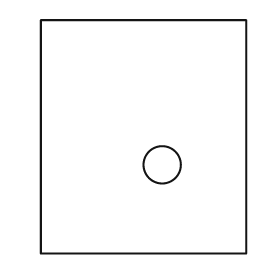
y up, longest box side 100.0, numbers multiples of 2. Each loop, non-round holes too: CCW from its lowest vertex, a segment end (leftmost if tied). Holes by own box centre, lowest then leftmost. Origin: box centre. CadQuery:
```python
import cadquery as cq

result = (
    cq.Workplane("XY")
    .moveTo(-44.0, -50.0)
    .lineTo(44.0, -50.0)
    .lineTo(44.0, 50.0)
    .lineTo(-44.0, 50.0)
    .close()
    .moveTo(8.0, -12.0)
    .circle(8.0)
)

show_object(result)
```